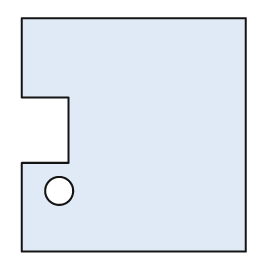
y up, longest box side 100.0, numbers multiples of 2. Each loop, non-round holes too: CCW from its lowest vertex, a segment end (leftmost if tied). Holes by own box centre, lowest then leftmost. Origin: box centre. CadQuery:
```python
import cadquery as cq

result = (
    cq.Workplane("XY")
    .moveTo(-48.0, -50.0)
    .lineTo(48.0, -50.0)
    .lineTo(48.0, 50.0)
    .lineTo(-48.0, 50.0)
    .lineTo(-48.0, 16.0)
    .lineTo(-28.0, 16.0)
    .lineTo(-28.0, -12.0)
    .lineTo(-48.0, -12.0)
    .close()
    .moveTo(-32.0, -24.0)
    .circle(6.0)
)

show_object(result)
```